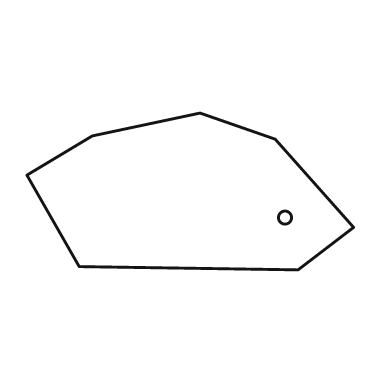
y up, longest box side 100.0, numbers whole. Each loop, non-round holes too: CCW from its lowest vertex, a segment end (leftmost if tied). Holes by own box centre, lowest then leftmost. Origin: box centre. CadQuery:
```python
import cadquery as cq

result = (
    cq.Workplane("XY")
    .moveTo(33.0, -24.0)
    .lineTo(50.0, -11.0)
    .lineTo(26.0, 16.0)
    .lineTo(3.0, 24.0)
    .lineTo(-30.0, 17.0)
    .lineTo(-50.0, 5.0)
    .lineTo(-34.0, -23.0)
    .close()
    .moveTo(29.0, -8.0)
    .circle(2.0)
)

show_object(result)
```